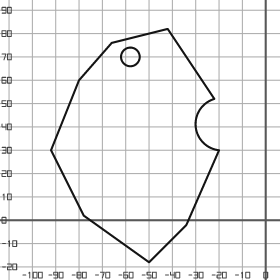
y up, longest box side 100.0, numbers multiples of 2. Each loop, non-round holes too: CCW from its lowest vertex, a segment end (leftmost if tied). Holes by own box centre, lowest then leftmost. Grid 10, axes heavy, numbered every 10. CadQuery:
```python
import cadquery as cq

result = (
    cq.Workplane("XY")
    .moveTo(-50.0, -18.0)
    .lineTo(-34.0, -2.0)
    .lineTo(-20.0, 30.0)
    .threePointArc((-30.0, 40.0), (-22.0, 52.0))
    .lineTo(-42.0, 82.0)
    .lineTo(-66.0, 76.0)
    .lineTo(-80.0, 60.0)
    .lineTo(-92.0, 30.0)
    .lineTo(-78.0, 2.0)
    .close()
    .moveTo(-58.0, 70.0)
    .circle(4.0)
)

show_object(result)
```